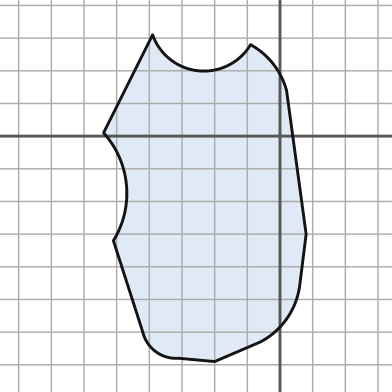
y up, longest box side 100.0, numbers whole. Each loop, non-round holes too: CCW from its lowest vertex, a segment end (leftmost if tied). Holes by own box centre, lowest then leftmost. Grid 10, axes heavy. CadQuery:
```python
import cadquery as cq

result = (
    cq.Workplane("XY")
    .moveTo(-20.0, -69.0)
    .lineTo(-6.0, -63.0)
    .threePointArc((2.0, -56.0), (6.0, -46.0))
    .lineTo(8.0, -30.0)
    .lineTo(2.0, 14.0)
    .threePointArc((-2.0, 22.0), (-9.0, 28.0))
    .threePointArc((-25.0, 20.0), (-39.0, 31.0))
    .lineTo(-54.0, 1.0)
    .threePointArc((-47.0, -15.0), (-51.0, -32.0))
    .lineTo(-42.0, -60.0)
    .threePointArc((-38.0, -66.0), (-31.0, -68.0))
    .close()
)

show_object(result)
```